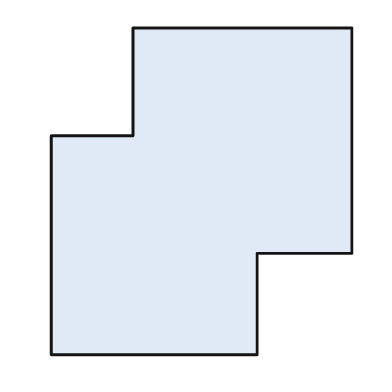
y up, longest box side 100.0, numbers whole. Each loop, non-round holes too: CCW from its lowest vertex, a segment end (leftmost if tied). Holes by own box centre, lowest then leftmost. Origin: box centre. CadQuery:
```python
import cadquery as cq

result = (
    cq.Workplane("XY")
    .moveTo(-46.0, -50.0)
    .lineTo(17.0, -50.0)
    .lineTo(17.0, -19.0)
    .lineTo(46.0, -19.0)
    .lineTo(46.0, 50.0)
    .lineTo(-21.0, 50.0)
    .lineTo(-21.0, 17.0)
    .lineTo(-46.0, 17.0)
    .close()
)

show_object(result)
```